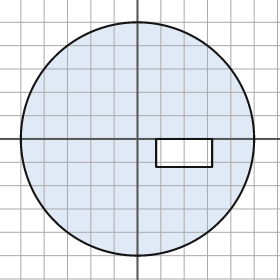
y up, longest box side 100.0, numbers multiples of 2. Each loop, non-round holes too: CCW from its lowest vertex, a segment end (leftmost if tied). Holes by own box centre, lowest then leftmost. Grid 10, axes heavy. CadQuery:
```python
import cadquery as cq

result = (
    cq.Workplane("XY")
    .moveTo(0.0, 0.0)
    .circle(50.0)
    .moveTo(8.0, -12.0)
    .lineTo(32.0, -12.0)
    .lineTo(32.0, 0.0)
    .lineTo(8.0, 0.0)
    .close()
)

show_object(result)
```